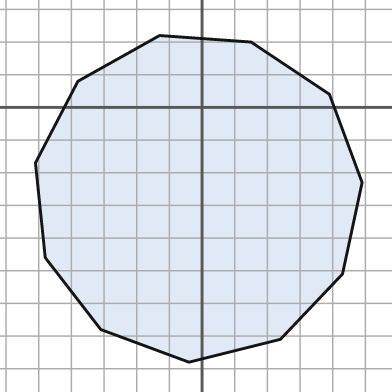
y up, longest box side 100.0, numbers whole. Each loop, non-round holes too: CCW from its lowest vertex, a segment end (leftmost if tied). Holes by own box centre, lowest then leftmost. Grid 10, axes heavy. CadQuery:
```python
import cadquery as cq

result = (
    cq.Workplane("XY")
    .moveTo(-4.0, -78.0)
    .lineTo(24.0, -71.0)
    .lineTo(43.0, -51.0)
    .lineTo(49.0, -23.0)
    .lineTo(39.0, 4.0)
    .lineTo(15.0, 20.0)
    .lineTo(-13.0, 22.0)
    .lineTo(-38.0, 8.0)
    .lineTo(-51.0, -17.0)
    .lineTo(-48.0, -46.0)
    .lineTo(-31.0, -68.0)
    .close()
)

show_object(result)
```